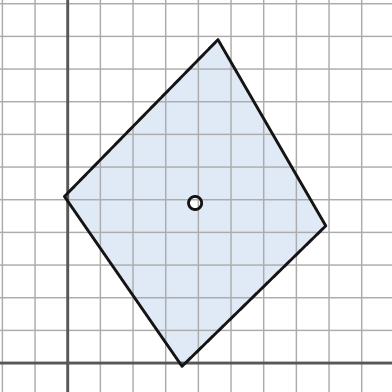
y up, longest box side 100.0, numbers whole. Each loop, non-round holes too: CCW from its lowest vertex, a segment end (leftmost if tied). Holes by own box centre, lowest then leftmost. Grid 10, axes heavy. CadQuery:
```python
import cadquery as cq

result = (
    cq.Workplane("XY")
    .moveTo(35.0, -1.0)
    .lineTo(79.0, 42.0)
    .lineTo(46.0, 99.0)
    .lineTo(-1.0, 51.0)
    .close()
    .moveTo(39.0, 49.0)
    .circle(2.0)
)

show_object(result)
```